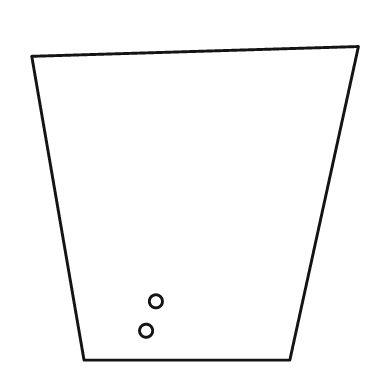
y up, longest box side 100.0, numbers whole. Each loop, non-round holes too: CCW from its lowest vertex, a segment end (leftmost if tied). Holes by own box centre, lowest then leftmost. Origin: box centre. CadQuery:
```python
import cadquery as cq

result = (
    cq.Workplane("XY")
    .moveTo(-34.0, -48.0)
    .lineTo(29.0, -48.0)
    .lineTo(50.0, 48.0)
    .lineTo(-50.0, 45.0)
    .close()
    .moveTo(-15.0, -39.0)
    .circle(2.0)
    .moveTo(-12.0, -30.0)
    .circle(2.0)
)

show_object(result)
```